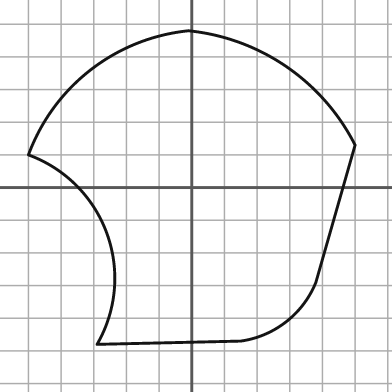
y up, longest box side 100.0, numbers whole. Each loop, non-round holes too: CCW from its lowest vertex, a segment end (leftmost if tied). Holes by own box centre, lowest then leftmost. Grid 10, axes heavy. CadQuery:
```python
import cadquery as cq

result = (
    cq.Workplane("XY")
    .moveTo(-29.0, -48.0)
    .lineTo(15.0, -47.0)
    .threePointArc((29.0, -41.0), (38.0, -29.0))
    .lineTo(50.0, 13.0)
    .threePointArc((29.0, 37.0), (-1.0, 48.0))
    .threePointArc((-31.0, 36.0), (-50.0, 10.0))
    .threePointArc((-26.0, -14.0), (-29.0, -48.0))
    .close()
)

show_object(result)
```